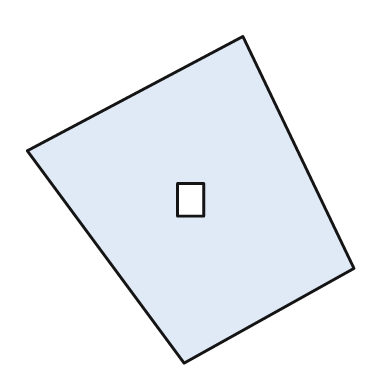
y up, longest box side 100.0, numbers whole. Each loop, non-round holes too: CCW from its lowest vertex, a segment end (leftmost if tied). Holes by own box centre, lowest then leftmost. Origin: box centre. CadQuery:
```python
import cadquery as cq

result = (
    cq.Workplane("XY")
    .moveTo(-2.0, -50.0)
    .lineTo(50.0, -21.0)
    .lineTo(16.0, 50.0)
    .lineTo(-50.0, 15.0)
    .close()
    .moveTo(-4.0, -5.0)
    .lineTo(4.0, -5.0)
    .lineTo(4.0, 5.0)
    .lineTo(-4.0, 5.0)
    .close()
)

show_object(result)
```